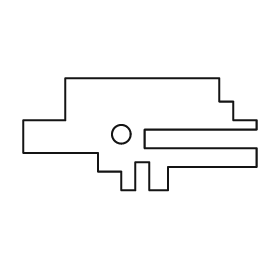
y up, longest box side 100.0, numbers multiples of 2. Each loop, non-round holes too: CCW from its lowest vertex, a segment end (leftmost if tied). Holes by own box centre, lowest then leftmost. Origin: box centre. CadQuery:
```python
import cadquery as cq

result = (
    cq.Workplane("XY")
    .moveTo(-8.0, -24.0)
    .lineTo(-2.0, -24.0)
    .lineTo(-2.0, -12.0)
    .lineTo(4.0, -12.0)
    .lineTo(4.0, -24.0)
    .lineTo(12.0, -24.0)
    .lineTo(12.0, -14.0)
    .lineTo(50.0, -14.0)
    .lineTo(50.0, -6.0)
    .lineTo(2.0, -6.0)
    .lineTo(2.0, 2.0)
    .lineTo(50.0, 2.0)
    .lineTo(50.0, 6.0)
    .lineTo(40.0, 6.0)
    .lineTo(40.0, 14.0)
    .lineTo(34.0, 14.0)
    .lineTo(34.0, 24.0)
    .lineTo(-32.0, 24.0)
    .lineTo(-32.0, 6.0)
    .lineTo(-50.0, 6.0)
    .lineTo(-50.0, -8.0)
    .lineTo(-18.0, -8.0)
    .lineTo(-18.0, -16.0)
    .lineTo(-8.0, -16.0)
    .close()
    .moveTo(-8.0, 0.0)
    .circle(4.0)
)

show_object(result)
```